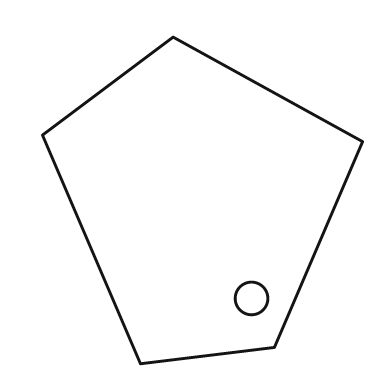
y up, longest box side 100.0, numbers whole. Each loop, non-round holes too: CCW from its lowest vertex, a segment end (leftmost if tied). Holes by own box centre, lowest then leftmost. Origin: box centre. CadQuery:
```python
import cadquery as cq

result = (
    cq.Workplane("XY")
    .moveTo(-19.0, -50.0)
    .lineTo(22.0, -45.0)
    .lineTo(49.0, 18.0)
    .lineTo(-9.0, 50.0)
    .lineTo(-49.0, 20.0)
    .close()
    .moveTo(15.0, -30.0)
    .circle(5.0)
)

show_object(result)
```